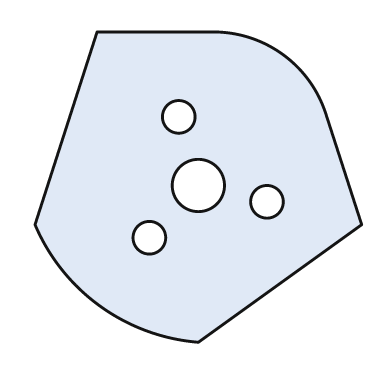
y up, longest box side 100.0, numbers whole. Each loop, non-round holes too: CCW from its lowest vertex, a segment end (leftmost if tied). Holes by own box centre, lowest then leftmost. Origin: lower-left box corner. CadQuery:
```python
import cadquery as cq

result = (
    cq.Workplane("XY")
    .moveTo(50.0, 0.0)
    .lineTo(100.0, 36.0)
    .lineTo(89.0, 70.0)
    .threePointArc((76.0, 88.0), (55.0, 95.0))
    .lineTo(19.0, 95.0)
    .lineTo(0.0, 36.0)
    .threePointArc((20.0, 11.0), (50.0, 0.0))
    .close()
    .moveTo(35.0, 32.0)
    .circle(5.0)
    .moveTo(71.0, 43.0)
    .circle(5.0)
    .moveTo(50.0, 48.0)
    .circle(8.0)
    .moveTo(44.0, 69.0)
    .circle(5.0)
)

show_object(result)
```